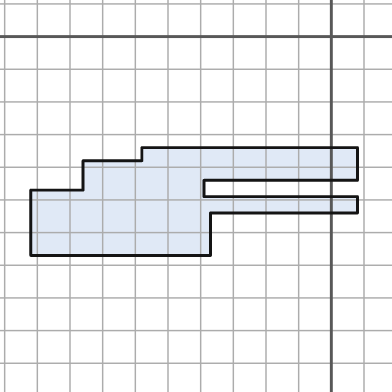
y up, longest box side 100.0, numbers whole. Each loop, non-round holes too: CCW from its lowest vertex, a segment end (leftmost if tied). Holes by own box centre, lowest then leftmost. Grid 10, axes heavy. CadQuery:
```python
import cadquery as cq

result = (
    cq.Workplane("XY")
    .moveTo(-92.0, -67.0)
    .lineTo(-37.0, -67.0)
    .lineTo(-37.0, -54.0)
    .lineTo(8.0, -54.0)
    .lineTo(8.0, -49.0)
    .lineTo(-39.0, -49.0)
    .lineTo(-39.0, -44.0)
    .lineTo(8.0, -44.0)
    .lineTo(8.0, -34.0)
    .lineTo(-58.0, -34.0)
    .lineTo(-58.0, -38.0)
    .lineTo(-76.0, -38.0)
    .lineTo(-76.0, -47.0)
    .lineTo(-92.0, -47.0)
    .close()
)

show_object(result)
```